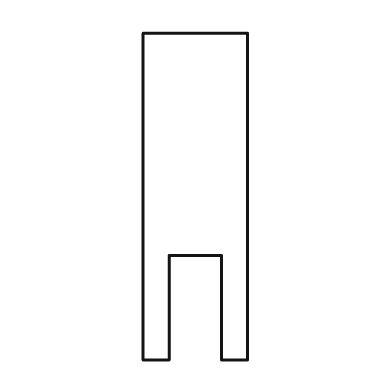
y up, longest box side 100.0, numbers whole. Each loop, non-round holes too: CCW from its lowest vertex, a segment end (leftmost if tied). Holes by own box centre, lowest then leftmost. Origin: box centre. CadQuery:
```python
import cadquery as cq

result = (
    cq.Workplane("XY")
    .moveTo(-16.0, -50.0)
    .lineTo(-8.0, -50.0)
    .lineTo(-8.0, -18.0)
    .lineTo(8.0, -18.0)
    .lineTo(8.0, -50.0)
    .lineTo(16.0, -50.0)
    .lineTo(16.0, 50.0)
    .lineTo(-16.0, 50.0)
    .close()
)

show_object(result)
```